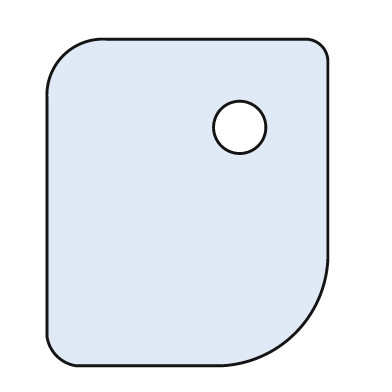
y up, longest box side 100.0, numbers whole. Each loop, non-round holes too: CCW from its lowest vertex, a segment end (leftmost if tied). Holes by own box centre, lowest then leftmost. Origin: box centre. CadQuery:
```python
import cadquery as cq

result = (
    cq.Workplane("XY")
    .moveTo(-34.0, -50.0)
    .lineTo(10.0, -50.0)
    .threePointArc((33.0, -40.0), (43.0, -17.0))
    .lineTo(43.0, 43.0)
    .threePointArc((41.0, 48.0), (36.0, 50.0))
    .lineTo(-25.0, 50.0)
    .threePointArc((-38.0, 45.0), (-43.0, 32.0))
    .lineTo(-43.0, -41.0)
    .threePointArc((-40.0, -47.0), (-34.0, -50.0))
    .close()
    .moveTo(16.0, 23.0)
    .circle(8.0)
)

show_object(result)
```